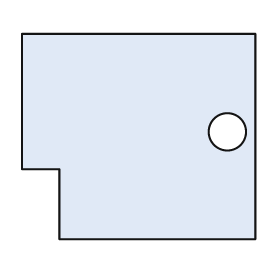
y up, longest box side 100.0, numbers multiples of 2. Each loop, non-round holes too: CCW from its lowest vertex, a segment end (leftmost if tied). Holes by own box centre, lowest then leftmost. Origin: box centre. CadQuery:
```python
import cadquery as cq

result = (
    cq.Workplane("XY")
    .moveTo(-34.0, -44.0)
    .lineTo(50.0, -44.0)
    .lineTo(50.0, 44.0)
    .lineTo(-50.0, 44.0)
    .lineTo(-50.0, -14.0)
    .lineTo(-34.0, -14.0)
    .close()
    .moveTo(38.0, 2.0)
    .circle(8.0)
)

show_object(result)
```